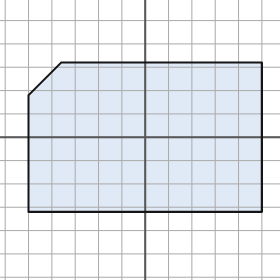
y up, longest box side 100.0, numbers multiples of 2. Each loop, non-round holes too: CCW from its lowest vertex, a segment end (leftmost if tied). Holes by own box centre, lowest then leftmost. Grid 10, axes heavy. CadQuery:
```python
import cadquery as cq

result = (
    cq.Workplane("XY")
    .moveTo(-50.0, -32.0)
    .lineTo(50.0, -32.0)
    .lineTo(50.0, 32.0)
    .lineTo(-36.0, 32.0)
    .lineTo(-50.0, 18.0)
    .close()
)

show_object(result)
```